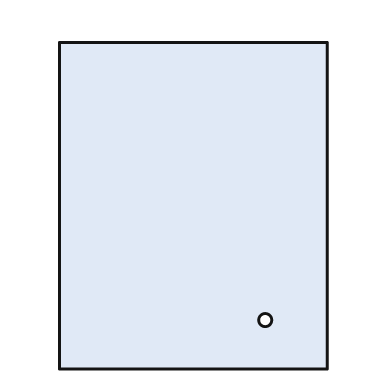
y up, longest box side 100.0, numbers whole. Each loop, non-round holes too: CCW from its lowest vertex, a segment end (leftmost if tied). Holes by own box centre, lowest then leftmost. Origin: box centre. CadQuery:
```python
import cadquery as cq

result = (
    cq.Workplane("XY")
    .moveTo(-41.0, -50.0)
    .lineTo(41.0, -50.0)
    .lineTo(41.0, 50.0)
    .lineTo(-41.0, 50.0)
    .close()
    .moveTo(22.0, -35.0)
    .circle(2.0)
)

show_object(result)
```